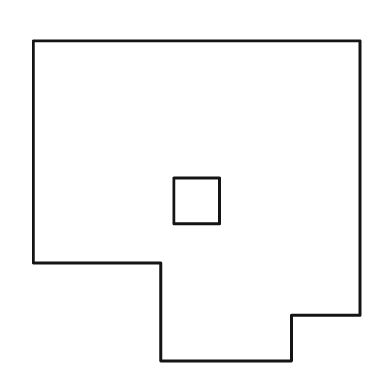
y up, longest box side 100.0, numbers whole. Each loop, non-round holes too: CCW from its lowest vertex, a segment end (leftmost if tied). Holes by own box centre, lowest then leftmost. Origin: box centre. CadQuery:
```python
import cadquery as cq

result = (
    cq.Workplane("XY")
    .moveTo(-11.0, -49.0)
    .lineTo(29.0, -49.0)
    .lineTo(29.0, -35.0)
    .lineTo(50.0, -35.0)
    .lineTo(50.0, 49.0)
    .lineTo(-50.0, 49.0)
    .lineTo(-50.0, -19.0)
    .lineTo(-11.0, -19.0)
    .close()
    .moveTo(-7.0, -7.0)
    .lineTo(7.0, -7.0)
    .lineTo(7.0, 7.0)
    .lineTo(-7.0, 7.0)
    .close()
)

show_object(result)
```